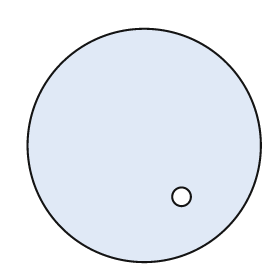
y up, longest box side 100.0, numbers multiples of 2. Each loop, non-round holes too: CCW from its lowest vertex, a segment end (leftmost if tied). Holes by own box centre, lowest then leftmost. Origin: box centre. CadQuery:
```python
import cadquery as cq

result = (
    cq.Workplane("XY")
    .moveTo(0.0, 0.0)
    .circle(50.0)
    .moveTo(16.0, -22.0)
    .circle(4.0)
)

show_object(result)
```